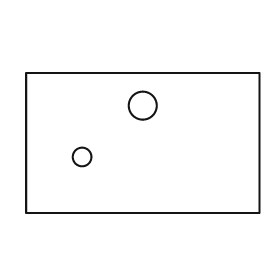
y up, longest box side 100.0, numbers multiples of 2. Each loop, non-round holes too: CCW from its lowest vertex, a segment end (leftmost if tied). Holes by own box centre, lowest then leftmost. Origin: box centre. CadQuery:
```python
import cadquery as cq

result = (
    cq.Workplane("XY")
    .moveTo(-50.0, -30.0)
    .lineTo(50.0, -30.0)
    .lineTo(50.0, 30.0)
    .lineTo(-50.0, 30.0)
    .close()
    .moveTo(-26.0, -6.0)
    .circle(4.0)
    .moveTo(0.0, 16.0)
    .circle(6.0)
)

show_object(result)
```